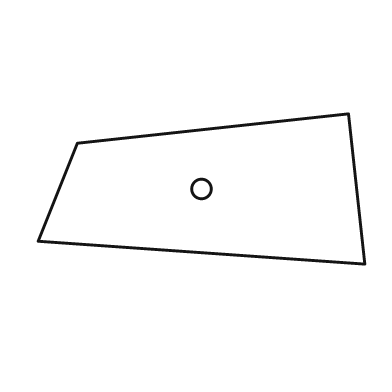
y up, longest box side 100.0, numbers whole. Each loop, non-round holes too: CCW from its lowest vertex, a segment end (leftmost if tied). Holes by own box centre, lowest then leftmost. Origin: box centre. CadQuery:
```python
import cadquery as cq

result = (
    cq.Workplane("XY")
    .moveTo(50.0, -23.0)
    .lineTo(45.0, 23.0)
    .lineTo(-38.0, 14.0)
    .lineTo(-50.0, -16.0)
    .close()
    .moveTo(0.0, 0.0)
    .circle(3.0)
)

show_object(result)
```